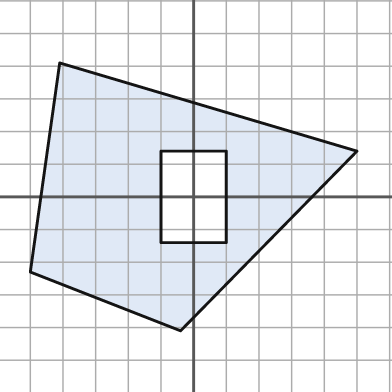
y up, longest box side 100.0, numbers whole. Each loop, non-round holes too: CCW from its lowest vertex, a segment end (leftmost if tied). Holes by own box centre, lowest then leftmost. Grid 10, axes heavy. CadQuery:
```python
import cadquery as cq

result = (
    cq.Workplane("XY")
    .moveTo(-4.0, -41.0)
    .lineTo(50.0, 14.0)
    .lineTo(-41.0, 41.0)
    .lineTo(-50.0, -23.0)
    .close()
    .moveTo(-10.0, -14.0)
    .lineTo(10.0, -14.0)
    .lineTo(10.0, 14.0)
    .lineTo(-10.0, 14.0)
    .close()
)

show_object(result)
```